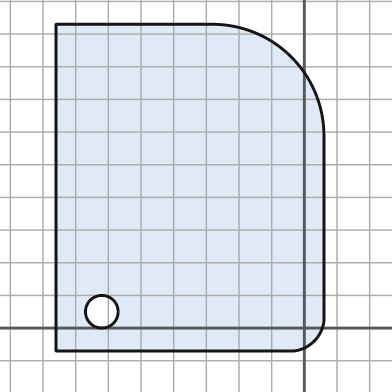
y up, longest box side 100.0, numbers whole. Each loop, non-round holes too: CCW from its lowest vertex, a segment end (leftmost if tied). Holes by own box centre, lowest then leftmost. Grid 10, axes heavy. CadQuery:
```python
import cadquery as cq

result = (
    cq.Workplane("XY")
    .moveTo(-76.0, -7.0)
    .lineTo(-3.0, -7.0)
    .threePointArc((3.0, -4.0), (6.0, 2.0))
    .lineTo(6.0, 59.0)
    .threePointArc((-4.0, 83.0), (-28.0, 93.0))
    .lineTo(-76.0, 93.0)
    .close()
    .moveTo(-62.0, 5.0)
    .circle(5.0)
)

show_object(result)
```